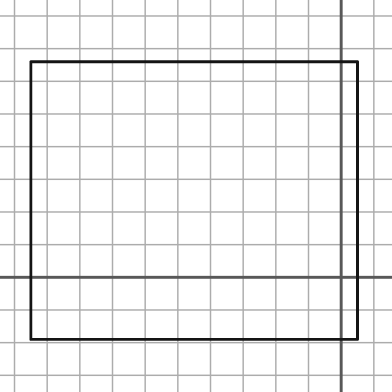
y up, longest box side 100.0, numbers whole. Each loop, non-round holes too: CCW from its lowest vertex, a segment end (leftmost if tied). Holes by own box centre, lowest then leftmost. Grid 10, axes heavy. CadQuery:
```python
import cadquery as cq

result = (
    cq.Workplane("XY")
    .moveTo(-95.0, -19.0)
    .lineTo(5.0, -19.0)
    .lineTo(5.0, 66.0)
    .lineTo(-95.0, 66.0)
    .close()
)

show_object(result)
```